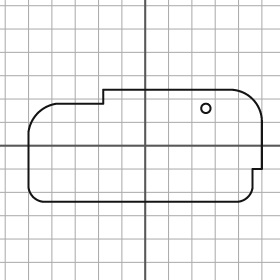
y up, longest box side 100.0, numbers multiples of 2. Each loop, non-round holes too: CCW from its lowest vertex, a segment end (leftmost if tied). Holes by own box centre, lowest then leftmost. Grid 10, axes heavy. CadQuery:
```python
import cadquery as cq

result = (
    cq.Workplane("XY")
    .moveTo(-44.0, -24.0)
    .lineTo(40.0, -24.0)
    .threePointArc((44.0, -22.0), (46.0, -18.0))
    .lineTo(46.0, -10.0)
    .lineTo(50.0, -10.0)
    .lineTo(50.0, 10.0)
    .threePointArc((46.0, 20.0), (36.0, 24.0))
    .lineTo(-18.0, 24.0)
    .lineTo(-18.0, 18.0)
    .lineTo(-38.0, 18.0)
    .threePointArc((-46.0, 14.0), (-50.0, 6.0))
    .lineTo(-50.0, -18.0)
    .threePointArc((-48.0, -22.0), (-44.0, -24.0))
    .close()
    .moveTo(26.0, 16.0)
    .circle(2.0)
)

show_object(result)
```